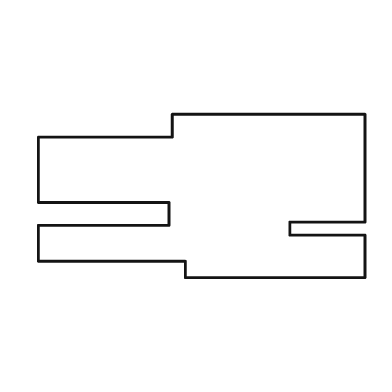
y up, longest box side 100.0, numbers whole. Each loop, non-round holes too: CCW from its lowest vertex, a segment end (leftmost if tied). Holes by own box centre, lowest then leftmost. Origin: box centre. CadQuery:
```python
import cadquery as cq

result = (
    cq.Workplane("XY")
    .moveTo(-5.0, -25.0)
    .lineTo(50.0, -25.0)
    .lineTo(50.0, -12.0)
    .lineTo(27.0, -12.0)
    .lineTo(27.0, -8.0)
    .lineTo(50.0, -8.0)
    .lineTo(50.0, 25.0)
    .lineTo(-9.0, 25.0)
    .lineTo(-9.0, 18.0)
    .lineTo(-50.0, 18.0)
    .lineTo(-50.0, -2.0)
    .lineTo(-10.0, -2.0)
    .lineTo(-10.0, -9.0)
    .lineTo(-50.0, -9.0)
    .lineTo(-50.0, -20.0)
    .lineTo(-5.0, -20.0)
    .close()
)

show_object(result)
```